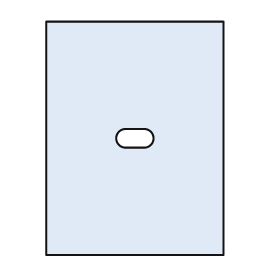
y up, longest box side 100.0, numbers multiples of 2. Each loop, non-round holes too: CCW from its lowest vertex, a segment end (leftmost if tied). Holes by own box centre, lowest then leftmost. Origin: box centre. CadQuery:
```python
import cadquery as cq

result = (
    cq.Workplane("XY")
    .moveTo(-38.0, -50.0)
    .lineTo(38.0, -50.0)
    .lineTo(38.0, 50.0)
    .lineTo(-38.0, 50.0)
    .close()
    .moveTo(-4.0, -4.0)
    .lineTo(4.0, -4.0)
    .threePointArc((8.0, 0.0), (4.0, 4.0))
    .lineTo(-4.0, 4.0)
    .threePointArc((-8.0, 0.0), (-4.0, -4.0))
    .close()
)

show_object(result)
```